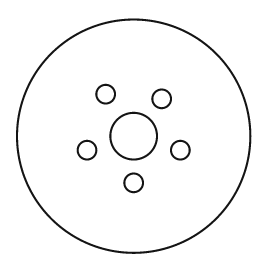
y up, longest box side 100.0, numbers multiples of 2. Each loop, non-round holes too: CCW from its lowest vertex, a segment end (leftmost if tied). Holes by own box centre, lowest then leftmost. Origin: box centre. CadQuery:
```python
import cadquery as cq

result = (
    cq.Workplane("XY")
    .moveTo(0.0, 0.0)
    .circle(50.0)
    .moveTo(0.0, -20.0)
    .circle(4.0)
    .moveTo(-20.0, -6.0)
    .circle(4.0)
    .moveTo(20.0, -6.0)
    .circle(4.0)
    .moveTo(0.0, 0.0)
    .circle(10.0)
    .moveTo(12.0, 16.0)
    .circle(4.0)
    .moveTo(-12.0, 18.0)
    .circle(4.0)
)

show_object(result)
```